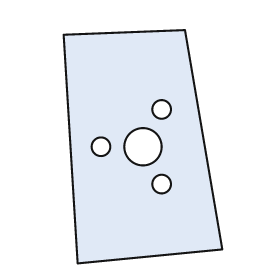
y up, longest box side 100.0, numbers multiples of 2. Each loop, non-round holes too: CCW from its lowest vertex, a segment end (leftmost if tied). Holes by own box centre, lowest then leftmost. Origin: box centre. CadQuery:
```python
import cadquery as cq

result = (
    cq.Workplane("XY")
    .moveTo(-28.0, -50.0)
    .lineTo(34.0, -44.0)
    .lineTo(18.0, 50.0)
    .lineTo(-34.0, 48.0)
    .close()
    .moveTo(8.0, -16.0)
    .circle(4.0)
    .moveTo(-18.0, 0.0)
    .circle(4.0)
    .moveTo(0.0, 0.0)
    .circle(8.0)
    .moveTo(8.0, 16.0)
    .circle(4.0)
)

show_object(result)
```